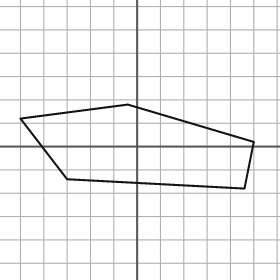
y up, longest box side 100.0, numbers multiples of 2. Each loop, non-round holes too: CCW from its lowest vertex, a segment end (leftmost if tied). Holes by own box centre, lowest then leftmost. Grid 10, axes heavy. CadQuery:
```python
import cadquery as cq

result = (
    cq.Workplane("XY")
    .moveTo(46.0, -18.0)
    .lineTo(50.0, 2.0)
    .lineTo(-4.0, 18.0)
    .lineTo(-50.0, 12.0)
    .lineTo(-30.0, -14.0)
    .close()
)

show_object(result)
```